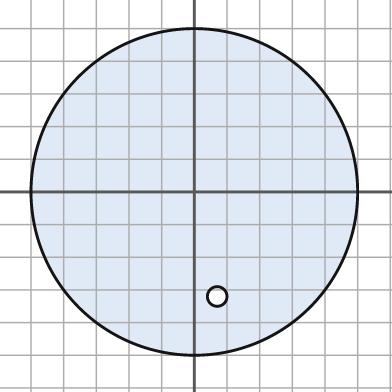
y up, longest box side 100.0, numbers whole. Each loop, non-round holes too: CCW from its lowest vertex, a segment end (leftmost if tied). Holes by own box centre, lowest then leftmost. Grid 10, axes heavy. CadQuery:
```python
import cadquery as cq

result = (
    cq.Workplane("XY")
    .moveTo(0.0, 0.0)
    .circle(50.0)
    .moveTo(7.0, -32.0)
    .circle(3.0)
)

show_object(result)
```